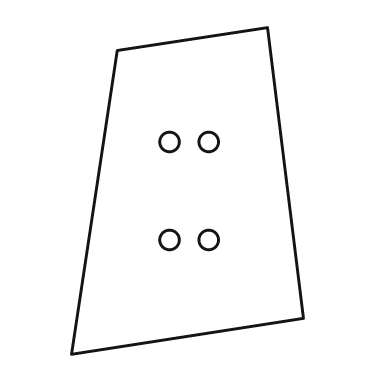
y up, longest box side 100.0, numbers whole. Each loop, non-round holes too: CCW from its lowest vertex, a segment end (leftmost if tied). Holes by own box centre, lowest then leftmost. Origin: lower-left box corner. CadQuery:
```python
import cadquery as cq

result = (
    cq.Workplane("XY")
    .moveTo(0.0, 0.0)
    .lineTo(71.0, 11.0)
    .lineTo(60.0, 100.0)
    .lineTo(14.0, 93.0)
    .close()
    .moveTo(30.0, 35.0)
    .circle(3.0)
    .moveTo(42.0, 35.0)
    .circle(3.0)
    .moveTo(30.0, 65.0)
    .circle(3.0)
    .moveTo(42.0, 65.0)
    .circle(3.0)
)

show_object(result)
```